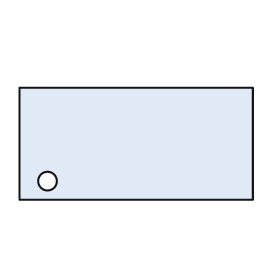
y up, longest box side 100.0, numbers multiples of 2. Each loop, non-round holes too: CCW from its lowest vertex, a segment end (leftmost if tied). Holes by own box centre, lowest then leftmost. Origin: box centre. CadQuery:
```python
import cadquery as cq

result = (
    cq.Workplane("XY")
    .moveTo(-50.0, -24.0)
    .lineTo(50.0, -24.0)
    .lineTo(50.0, 24.0)
    .lineTo(-50.0, 24.0)
    .close()
    .moveTo(-38.0, -16.0)
    .circle(4.0)
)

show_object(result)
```